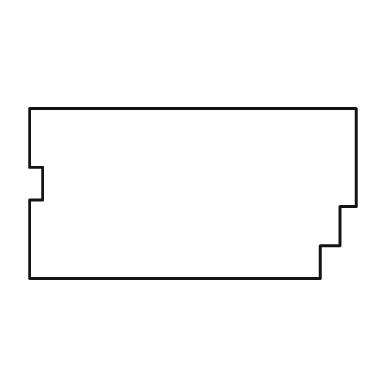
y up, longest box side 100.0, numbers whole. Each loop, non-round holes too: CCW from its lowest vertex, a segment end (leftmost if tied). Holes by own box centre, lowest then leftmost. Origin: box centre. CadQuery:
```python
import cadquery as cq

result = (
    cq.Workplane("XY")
    .moveTo(-50.0, -26.0)
    .lineTo(39.0, -26.0)
    .lineTo(39.0, -16.0)
    .lineTo(45.0, -16.0)
    .lineTo(45.0, -4.0)
    .lineTo(50.0, -4.0)
    .lineTo(50.0, 26.0)
    .lineTo(-50.0, 26.0)
    .lineTo(-50.0, 8.0)
    .lineTo(-46.0, 8.0)
    .lineTo(-46.0, -2.0)
    .lineTo(-50.0, -2.0)
    .close()
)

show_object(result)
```